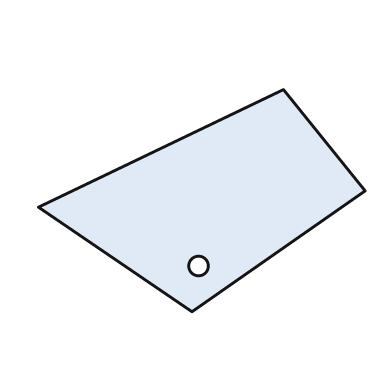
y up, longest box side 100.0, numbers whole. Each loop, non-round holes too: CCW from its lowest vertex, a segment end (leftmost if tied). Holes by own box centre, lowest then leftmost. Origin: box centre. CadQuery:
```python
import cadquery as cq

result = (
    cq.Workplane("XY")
    .moveTo(-3.0, -34.0)
    .lineTo(50.0, 3.0)
    .lineTo(25.0, 34.0)
    .lineTo(-50.0, -2.0)
    .close()
    .moveTo(-1.0, -20.0)
    .circle(3.0)
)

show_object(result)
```